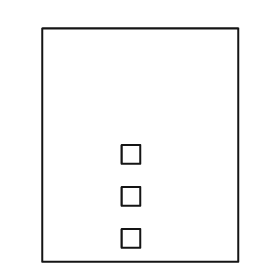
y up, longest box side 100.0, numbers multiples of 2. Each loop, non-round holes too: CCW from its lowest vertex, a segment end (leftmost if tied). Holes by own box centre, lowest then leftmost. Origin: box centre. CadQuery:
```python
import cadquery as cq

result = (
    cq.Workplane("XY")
    .moveTo(-42.0, -50.0)
    .lineTo(42.0, -50.0)
    .lineTo(42.0, 50.0)
    .lineTo(-42.0, 50.0)
    .close()
    .moveTo(-8.0, -44.0)
    .lineTo(0.0, -44.0)
    .lineTo(0.0, -36.0)
    .lineTo(-8.0, -36.0)
    .close()
    .moveTo(-8.0, -26.0)
    .lineTo(0.0, -26.0)
    .lineTo(0.0, -18.0)
    .lineTo(-8.0, -18.0)
    .close()
    .moveTo(-8.0, -8.0)
    .lineTo(0.0, -8.0)
    .lineTo(0.0, 0.0)
    .lineTo(-8.0, 0.0)
    .close()
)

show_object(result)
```